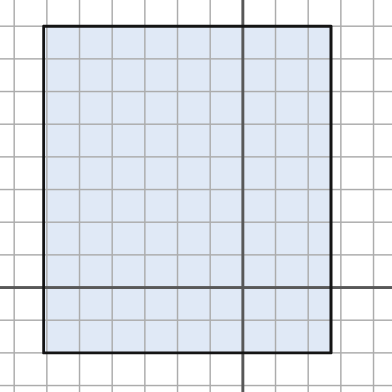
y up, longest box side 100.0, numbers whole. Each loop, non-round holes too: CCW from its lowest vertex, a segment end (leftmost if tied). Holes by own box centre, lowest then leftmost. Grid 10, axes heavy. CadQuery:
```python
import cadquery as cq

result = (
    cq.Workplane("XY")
    .moveTo(-61.0, -20.0)
    .lineTo(27.0, -20.0)
    .lineTo(27.0, 80.0)
    .lineTo(-61.0, 80.0)
    .close()
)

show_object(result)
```